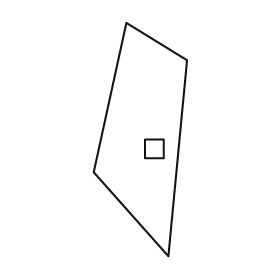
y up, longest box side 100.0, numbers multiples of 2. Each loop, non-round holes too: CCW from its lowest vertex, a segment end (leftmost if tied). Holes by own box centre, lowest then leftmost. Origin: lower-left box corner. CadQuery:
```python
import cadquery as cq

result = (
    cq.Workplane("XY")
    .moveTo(32.0, 0.0)
    .lineTo(40.0, 84.0)
    .lineTo(14.0, 100.0)
    .lineTo(0.0, 36.0)
    .close()
    .moveTo(22.0, 42.0)
    .lineTo(30.0, 42.0)
    .lineTo(30.0, 50.0)
    .lineTo(22.0, 50.0)
    .close()
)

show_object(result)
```